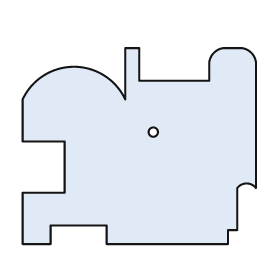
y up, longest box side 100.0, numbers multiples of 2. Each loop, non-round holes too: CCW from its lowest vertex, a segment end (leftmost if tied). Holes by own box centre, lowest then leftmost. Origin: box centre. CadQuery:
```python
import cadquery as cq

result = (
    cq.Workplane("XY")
    .moveTo(-50.0, -42.0)
    .lineTo(-38.0, -42.0)
    .lineTo(-38.0, -34.0)
    .lineTo(-14.0, -34.0)
    .lineTo(-14.0, -42.0)
    .lineTo(38.0, -42.0)
    .lineTo(38.0, -36.0)
    .lineTo(42.0, -36.0)
    .lineTo(42.0, -18.0)
    .threePointArc((46.0, -16.0), (50.0, -18.0))
    .lineTo(50.0, 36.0)
    .threePointArc((48.0, 40.0), (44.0, 42.0))
    .lineTo(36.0, 42.0)
    .threePointArc((32.0, 40.0), (30.0, 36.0))
    .lineTo(30.0, 28.0)
    .lineTo(0.0, 28.0)
    .lineTo(0.0, 42.0)
    .lineTo(-6.0, 42.0)
    .lineTo(-6.0, 20.0)
    .threePointArc((-28.0, 34.0), (-50.0, 20.0))
    .lineTo(-50.0, 2.0)
    .lineTo(-32.0, 2.0)
    .lineTo(-32.0, -20.0)
    .lineTo(-50.0, -20.0)
    .close()
    .moveTo(6.0, 6.0)
    .circle(2.0)
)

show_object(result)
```